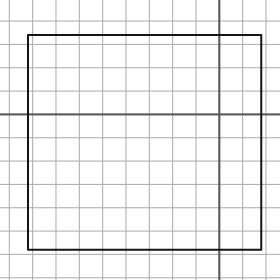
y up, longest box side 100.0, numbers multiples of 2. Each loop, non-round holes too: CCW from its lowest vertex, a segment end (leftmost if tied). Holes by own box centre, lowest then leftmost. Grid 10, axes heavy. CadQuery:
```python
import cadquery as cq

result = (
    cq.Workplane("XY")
    .moveTo(-82.0, -58.0)
    .lineTo(18.0, -58.0)
    .lineTo(18.0, 34.0)
    .lineTo(-82.0, 34.0)
    .close()
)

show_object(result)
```